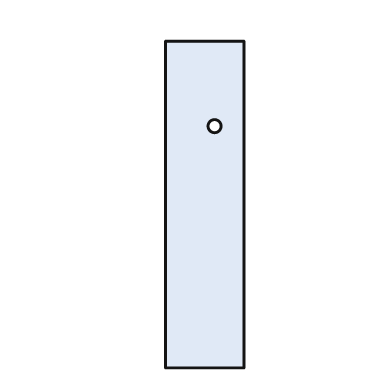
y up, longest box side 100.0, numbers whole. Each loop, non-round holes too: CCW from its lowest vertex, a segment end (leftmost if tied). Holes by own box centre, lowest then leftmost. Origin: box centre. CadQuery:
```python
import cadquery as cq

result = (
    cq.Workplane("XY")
    .moveTo(-12.0, -50.0)
    .lineTo(12.0, -50.0)
    .lineTo(12.0, 50.0)
    .lineTo(-12.0, 50.0)
    .close()
    .moveTo(3.0, 24.0)
    .circle(2.0)
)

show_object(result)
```